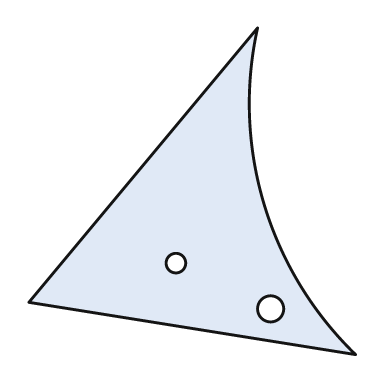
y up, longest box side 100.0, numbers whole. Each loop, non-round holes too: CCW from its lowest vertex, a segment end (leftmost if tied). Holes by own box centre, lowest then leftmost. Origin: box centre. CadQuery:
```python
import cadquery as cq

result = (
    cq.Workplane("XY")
    .moveTo(50.0, -50.0)
    .threePointArc((22.0, -4.0), (20.0, 50.0))
    .lineTo(-50.0, -34.0)
    .close()
    .moveTo(24.0, -36.0)
    .circle(4.0)
    .moveTo(-5.0, -22.0)
    .circle(3.0)
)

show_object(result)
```